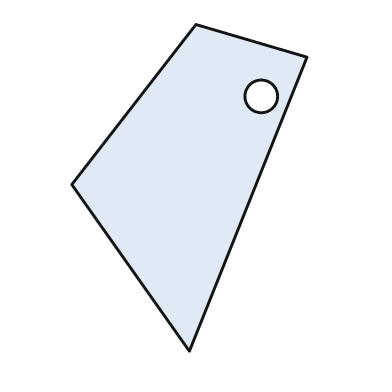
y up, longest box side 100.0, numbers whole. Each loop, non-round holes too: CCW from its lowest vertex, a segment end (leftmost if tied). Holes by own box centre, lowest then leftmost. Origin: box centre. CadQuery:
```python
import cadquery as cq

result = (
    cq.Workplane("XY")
    .moveTo(0.0, -50.0)
    .lineTo(36.0, 40.0)
    .lineTo(2.0, 50.0)
    .lineTo(-36.0, 1.0)
    .close()
    .moveTo(22.0, 28.0)
    .circle(5.0)
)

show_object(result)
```